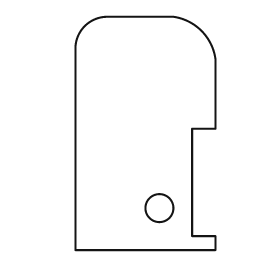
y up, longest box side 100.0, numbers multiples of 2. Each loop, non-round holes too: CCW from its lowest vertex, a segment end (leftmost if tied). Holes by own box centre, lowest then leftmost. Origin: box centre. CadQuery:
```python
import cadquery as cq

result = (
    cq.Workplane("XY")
    .moveTo(-30.0, -50.0)
    .lineTo(30.0, -50.0)
    .lineTo(30.0, -44.0)
    .lineTo(20.0, -44.0)
    .lineTo(20.0, 2.0)
    .lineTo(30.0, 2.0)
    .lineTo(30.0, 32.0)
    .threePointArc((24.0, 44.0), (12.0, 50.0))
    .lineTo(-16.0, 50.0)
    .threePointArc((-26.0, 46.0), (-30.0, 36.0))
    .close()
    .moveTo(6.0, -32.0)
    .circle(6.0)
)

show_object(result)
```